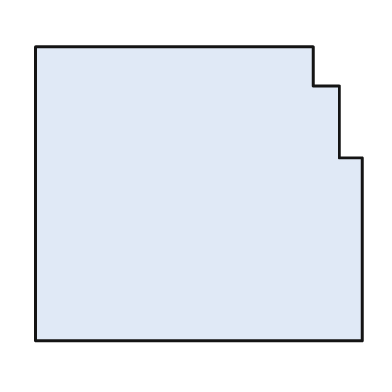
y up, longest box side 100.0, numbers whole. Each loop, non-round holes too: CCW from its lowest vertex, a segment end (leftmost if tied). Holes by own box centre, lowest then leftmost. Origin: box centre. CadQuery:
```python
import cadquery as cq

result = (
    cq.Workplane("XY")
    .moveTo(-50.0, -45.0)
    .lineTo(50.0, -45.0)
    .lineTo(50.0, 11.0)
    .lineTo(43.0, 11.0)
    .lineTo(43.0, 33.0)
    .lineTo(35.0, 33.0)
    .lineTo(35.0, 45.0)
    .lineTo(-50.0, 45.0)
    .close()
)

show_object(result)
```